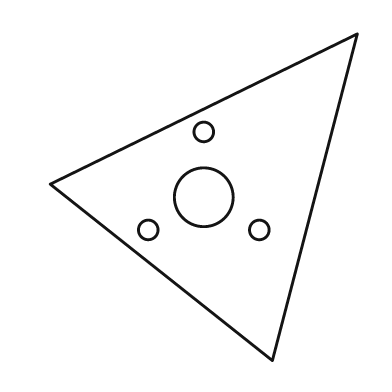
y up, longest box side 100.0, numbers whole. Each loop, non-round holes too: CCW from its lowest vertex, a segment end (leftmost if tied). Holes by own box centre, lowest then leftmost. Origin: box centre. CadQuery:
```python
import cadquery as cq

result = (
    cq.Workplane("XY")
    .moveTo(21.0, -50.0)
    .lineTo(47.0, 50.0)
    .lineTo(-47.0, 4.0)
    .close()
    .moveTo(-17.0, -10.0)
    .circle(3.0)
    .moveTo(17.0, -10.0)
    .circle(3.0)
    .moveTo(0.0, 0.0)
    .circle(9.0)
    .moveTo(0.0, 20.0)
    .circle(3.0)
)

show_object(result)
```